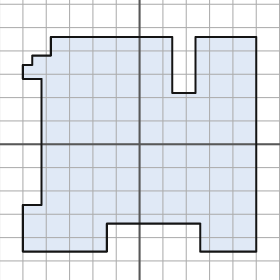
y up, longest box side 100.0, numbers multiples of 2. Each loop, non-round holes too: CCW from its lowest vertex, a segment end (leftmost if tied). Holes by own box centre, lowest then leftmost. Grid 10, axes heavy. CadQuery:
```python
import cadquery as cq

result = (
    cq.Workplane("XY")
    .moveTo(-50.0, -46.0)
    .lineTo(-14.0, -46.0)
    .lineTo(-14.0, -34.0)
    .lineTo(26.0, -34.0)
    .lineTo(26.0, -46.0)
    .lineTo(50.0, -46.0)
    .lineTo(50.0, 46.0)
    .lineTo(24.0, 46.0)
    .lineTo(24.0, 22.0)
    .lineTo(14.0, 22.0)
    .lineTo(14.0, 46.0)
    .lineTo(-38.0, 46.0)
    .lineTo(-38.0, 38.0)
    .lineTo(-46.0, 38.0)
    .lineTo(-46.0, 34.0)
    .lineTo(-50.0, 34.0)
    .lineTo(-50.0, 28.0)
    .lineTo(-42.0, 28.0)
    .lineTo(-42.0, -26.0)
    .lineTo(-50.0, -26.0)
    .close()
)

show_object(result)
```